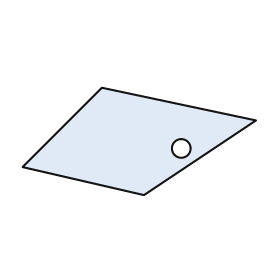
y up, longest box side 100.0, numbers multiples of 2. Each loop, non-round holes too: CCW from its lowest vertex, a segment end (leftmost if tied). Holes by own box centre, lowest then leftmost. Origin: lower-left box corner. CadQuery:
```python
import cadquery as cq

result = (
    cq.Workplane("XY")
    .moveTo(52.0, 0.0)
    .lineTo(100.0, 32.0)
    .lineTo(34.0, 46.0)
    .lineTo(0.0, 12.0)
    .close()
    .moveTo(68.0, 20.0)
    .circle(4.0)
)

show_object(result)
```